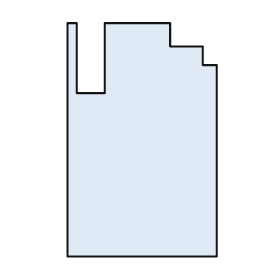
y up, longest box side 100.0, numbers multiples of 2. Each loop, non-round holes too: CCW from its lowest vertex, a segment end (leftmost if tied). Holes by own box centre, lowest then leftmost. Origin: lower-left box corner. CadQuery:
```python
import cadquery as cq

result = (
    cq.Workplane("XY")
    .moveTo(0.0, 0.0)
    .lineTo(64.0, 0.0)
    .lineTo(64.0, 82.0)
    .lineTo(58.0, 82.0)
    .lineTo(58.0, 90.0)
    .lineTo(44.0, 90.0)
    .lineTo(44.0, 100.0)
    .lineTo(16.0, 100.0)
    .lineTo(16.0, 70.0)
    .lineTo(4.0, 70.0)
    .lineTo(4.0, 100.0)
    .lineTo(0.0, 100.0)
    .close()
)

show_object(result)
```